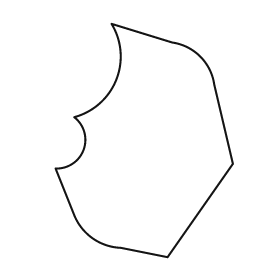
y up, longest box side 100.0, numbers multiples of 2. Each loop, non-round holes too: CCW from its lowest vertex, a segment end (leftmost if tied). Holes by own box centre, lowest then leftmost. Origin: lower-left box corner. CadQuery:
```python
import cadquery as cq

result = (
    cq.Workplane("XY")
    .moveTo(48.0, 0.0)
    .lineTo(76.0, 40.0)
    .lineTo(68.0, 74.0)
    .threePointArc((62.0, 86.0), (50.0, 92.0))
    .lineTo(24.0, 100.0)
    .threePointArc((26.0, 76.0), (8.0, 60.0))
    .threePointArc((12.0, 46.0), (0.0, 38.0))
    .lineTo(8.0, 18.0)
    .threePointArc((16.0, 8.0), (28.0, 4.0))
    .close()
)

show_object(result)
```